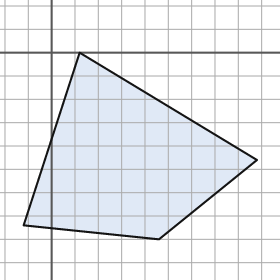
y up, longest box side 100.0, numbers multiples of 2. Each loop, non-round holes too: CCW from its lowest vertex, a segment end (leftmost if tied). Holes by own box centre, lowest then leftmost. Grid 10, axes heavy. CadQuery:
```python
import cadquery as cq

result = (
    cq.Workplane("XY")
    .moveTo(46.0, -80.0)
    .lineTo(88.0, -46.0)
    .lineTo(12.0, 0.0)
    .lineTo(-12.0, -74.0)
    .close()
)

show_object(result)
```